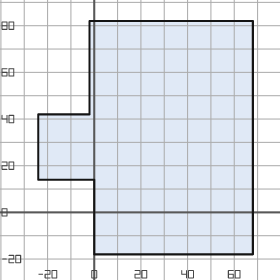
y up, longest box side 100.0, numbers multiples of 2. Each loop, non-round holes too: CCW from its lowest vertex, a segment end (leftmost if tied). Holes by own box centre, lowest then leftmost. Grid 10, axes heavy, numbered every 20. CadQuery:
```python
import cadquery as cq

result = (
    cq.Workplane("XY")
    .moveTo(0.0, -18.0)
    .lineTo(68.0, -18.0)
    .lineTo(68.0, 82.0)
    .lineTo(-2.0, 82.0)
    .lineTo(-2.0, 42.0)
    .lineTo(-24.0, 42.0)
    .lineTo(-24.0, 14.0)
    .lineTo(0.0, 14.0)
    .close()
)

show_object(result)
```